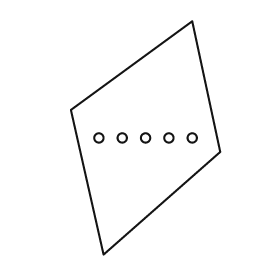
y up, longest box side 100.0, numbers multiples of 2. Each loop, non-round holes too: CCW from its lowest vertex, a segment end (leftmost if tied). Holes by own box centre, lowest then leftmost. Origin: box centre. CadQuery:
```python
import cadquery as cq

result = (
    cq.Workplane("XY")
    .moveTo(-18.0, -50.0)
    .lineTo(32.0, -6.0)
    .lineTo(20.0, 50.0)
    .lineTo(-32.0, 12.0)
    .close()
    .moveTo(-20.0, 0.0)
    .circle(2.0)
    .moveTo(-10.0, 0.0)
    .circle(2.0)
    .moveTo(0.0, 0.0)
    .circle(2.0)
    .moveTo(10.0, 0.0)
    .circle(2.0)
    .moveTo(20.0, 0.0)
    .circle(2.0)
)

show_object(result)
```